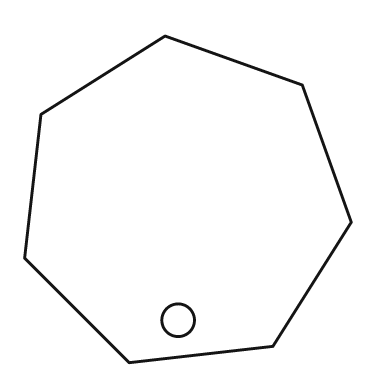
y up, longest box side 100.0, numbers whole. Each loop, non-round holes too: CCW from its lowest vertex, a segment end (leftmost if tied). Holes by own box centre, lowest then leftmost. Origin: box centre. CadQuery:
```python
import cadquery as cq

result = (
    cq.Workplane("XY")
    .moveTo(-18.0, -50.0)
    .lineTo(26.0, -45.0)
    .lineTo(50.0, -7.0)
    .lineTo(35.0, 35.0)
    .lineTo(-7.0, 50.0)
    .lineTo(-45.0, 26.0)
    .lineTo(-50.0, -18.0)
    .close()
    .moveTo(-3.0, -37.0)
    .circle(5.0)
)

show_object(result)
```